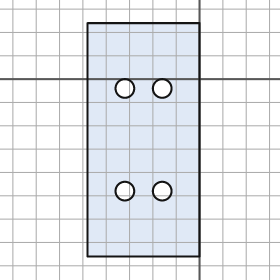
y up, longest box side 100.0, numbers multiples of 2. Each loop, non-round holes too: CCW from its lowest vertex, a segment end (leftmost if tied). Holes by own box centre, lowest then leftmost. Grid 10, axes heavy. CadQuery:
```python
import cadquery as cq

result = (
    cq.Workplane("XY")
    .moveTo(-48.0, -76.0)
    .lineTo(0.0, -76.0)
    .lineTo(0.0, 24.0)
    .lineTo(-48.0, 24.0)
    .close()
    .moveTo(-32.0, -48.0)
    .circle(4.0)
    .moveTo(-16.0, -48.0)
    .circle(4.0)
    .moveTo(-32.0, -4.0)
    .circle(4.0)
    .moveTo(-16.0, -4.0)
    .circle(4.0)
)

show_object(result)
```